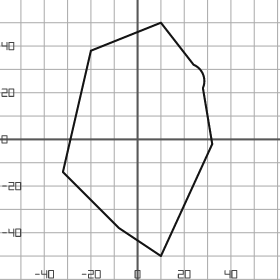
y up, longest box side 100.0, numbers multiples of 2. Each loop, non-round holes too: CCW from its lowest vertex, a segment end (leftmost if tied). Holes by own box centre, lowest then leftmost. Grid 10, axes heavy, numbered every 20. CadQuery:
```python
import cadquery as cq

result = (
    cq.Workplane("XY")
    .moveTo(10.0, -50.0)
    .lineTo(32.0, -2.0)
    .lineTo(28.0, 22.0)
    .threePointArc((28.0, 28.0), (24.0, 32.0))
    .lineTo(10.0, 50.0)
    .lineTo(-20.0, 38.0)
    .lineTo(-32.0, -14.0)
    .lineTo(-8.0, -38.0)
    .close()
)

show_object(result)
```